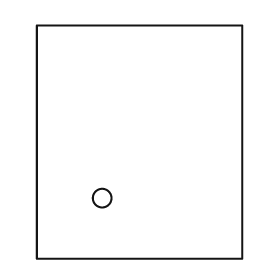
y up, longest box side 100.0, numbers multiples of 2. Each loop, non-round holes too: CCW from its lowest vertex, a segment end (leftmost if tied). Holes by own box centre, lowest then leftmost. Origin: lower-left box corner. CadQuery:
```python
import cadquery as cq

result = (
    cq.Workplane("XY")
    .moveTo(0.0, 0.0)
    .lineTo(88.0, 0.0)
    .lineTo(88.0, 100.0)
    .lineTo(0.0, 100.0)
    .close()
    .moveTo(28.0, 26.0)
    .circle(4.0)
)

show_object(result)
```